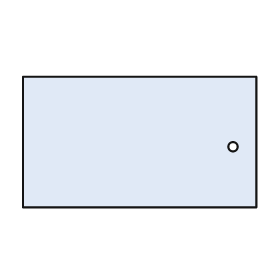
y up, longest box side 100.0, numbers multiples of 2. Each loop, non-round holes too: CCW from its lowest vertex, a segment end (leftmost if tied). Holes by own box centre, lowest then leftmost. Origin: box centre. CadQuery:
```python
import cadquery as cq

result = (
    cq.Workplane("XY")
    .moveTo(-50.0, -28.0)
    .lineTo(50.0, -28.0)
    .lineTo(50.0, 28.0)
    .lineTo(-50.0, 28.0)
    .close()
    .moveTo(40.0, -2.0)
    .circle(2.0)
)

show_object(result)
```